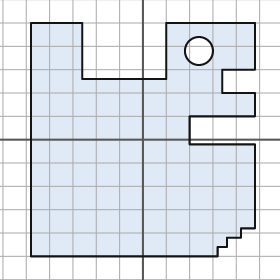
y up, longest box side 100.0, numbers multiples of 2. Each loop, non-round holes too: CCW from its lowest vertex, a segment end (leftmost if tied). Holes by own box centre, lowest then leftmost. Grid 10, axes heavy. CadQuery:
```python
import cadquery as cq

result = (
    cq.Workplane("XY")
    .moveTo(-48.0, -50.0)
    .lineTo(32.0, -50.0)
    .lineTo(32.0, -46.0)
    .lineTo(36.0, -46.0)
    .lineTo(36.0, -42.0)
    .lineTo(42.0, -42.0)
    .lineTo(42.0, -38.0)
    .lineTo(48.0, -38.0)
    .lineTo(48.0, -2.0)
    .lineTo(20.0, -2.0)
    .lineTo(20.0, 10.0)
    .lineTo(48.0, 10.0)
    .lineTo(48.0, 20.0)
    .lineTo(34.0, 20.0)
    .lineTo(34.0, 30.0)
    .lineTo(48.0, 30.0)
    .lineTo(48.0, 50.0)
    .lineTo(10.0, 50.0)
    .lineTo(10.0, 26.0)
    .lineTo(-26.0, 26.0)
    .lineTo(-26.0, 50.0)
    .lineTo(-48.0, 50.0)
    .close()
    .moveTo(24.0, 38.0)
    .circle(6.0)
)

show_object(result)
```